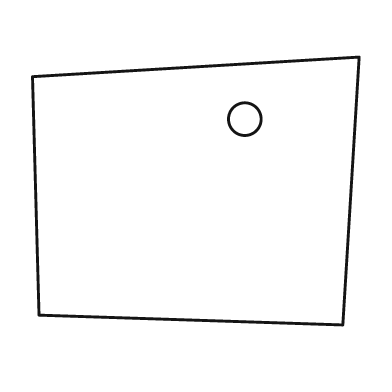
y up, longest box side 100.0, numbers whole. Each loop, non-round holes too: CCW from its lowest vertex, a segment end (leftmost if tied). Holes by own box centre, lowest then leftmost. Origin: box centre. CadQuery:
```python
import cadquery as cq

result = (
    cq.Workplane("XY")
    .moveTo(45.0, -41.0)
    .lineTo(50.0, 41.0)
    .lineTo(-50.0, 35.0)
    .lineTo(-48.0, -38.0)
    .close()
    .moveTo(15.0, 22.0)
    .circle(5.0)
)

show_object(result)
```